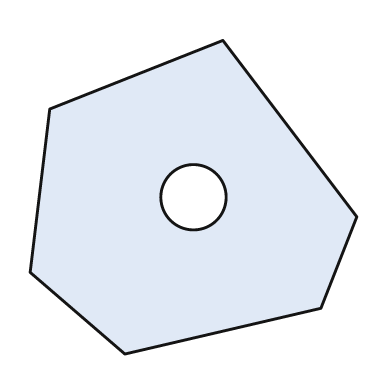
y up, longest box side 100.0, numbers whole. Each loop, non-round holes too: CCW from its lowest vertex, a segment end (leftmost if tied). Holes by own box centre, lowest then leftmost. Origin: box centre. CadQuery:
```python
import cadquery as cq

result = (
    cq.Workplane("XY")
    .moveTo(-21.0, -48.0)
    .lineTo(39.0, -34.0)
    .lineTo(50.0, -6.0)
    .lineTo(9.0, 48.0)
    .lineTo(-44.0, 27.0)
    .lineTo(-50.0, -23.0)
    .close()
    .moveTo(0.0, 0.0)
    .circle(10.0)
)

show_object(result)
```